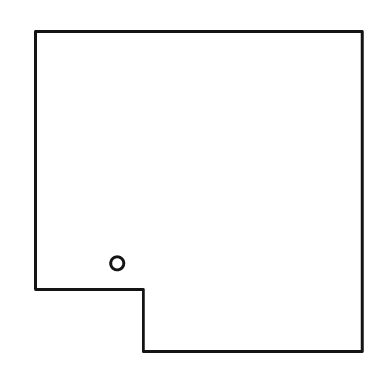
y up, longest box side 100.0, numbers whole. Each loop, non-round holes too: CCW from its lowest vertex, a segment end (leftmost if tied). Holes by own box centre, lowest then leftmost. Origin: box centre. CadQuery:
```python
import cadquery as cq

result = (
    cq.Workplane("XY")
    .moveTo(-17.0, -49.0)
    .lineTo(50.0, -49.0)
    .lineTo(50.0, 49.0)
    .lineTo(-50.0, 49.0)
    .lineTo(-50.0, -30.0)
    .lineTo(-17.0, -30.0)
    .close()
    .moveTo(-25.0, -22.0)
    .circle(2.0)
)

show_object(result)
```